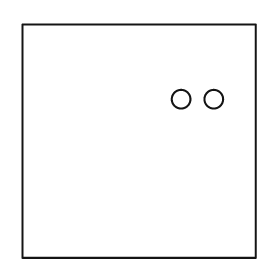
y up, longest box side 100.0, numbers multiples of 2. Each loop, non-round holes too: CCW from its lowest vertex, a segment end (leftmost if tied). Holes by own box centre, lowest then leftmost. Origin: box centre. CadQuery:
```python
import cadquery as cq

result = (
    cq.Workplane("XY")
    .moveTo(-50.0, -50.0)
    .lineTo(50.0, -50.0)
    .lineTo(50.0, 50.0)
    .lineTo(-50.0, 50.0)
    .close()
    .moveTo(18.0, 18.0)
    .circle(4.0)
    .moveTo(32.0, 18.0)
    .circle(4.0)
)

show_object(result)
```